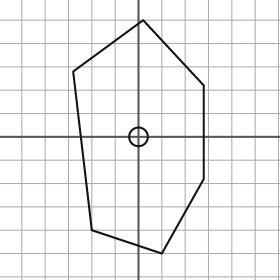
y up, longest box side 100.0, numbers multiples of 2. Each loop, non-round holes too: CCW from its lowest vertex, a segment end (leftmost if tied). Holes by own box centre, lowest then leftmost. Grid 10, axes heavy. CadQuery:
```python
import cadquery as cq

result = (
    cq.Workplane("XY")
    .moveTo(10.0, -50.0)
    .lineTo(28.0, -18.0)
    .lineTo(28.0, 22.0)
    .lineTo(2.0, 50.0)
    .lineTo(-28.0, 28.0)
    .lineTo(-20.0, -40.0)
    .close()
    .moveTo(0.0, 0.0)
    .circle(4.0)
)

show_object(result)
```